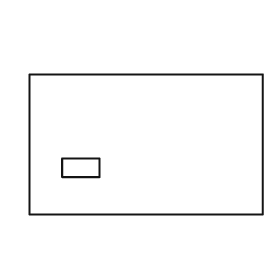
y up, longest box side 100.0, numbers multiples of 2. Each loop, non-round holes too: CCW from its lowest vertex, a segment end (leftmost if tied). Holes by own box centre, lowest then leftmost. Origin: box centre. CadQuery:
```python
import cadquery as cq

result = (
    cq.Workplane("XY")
    .moveTo(-50.0, -30.0)
    .lineTo(50.0, -30.0)
    .lineTo(50.0, 30.0)
    .lineTo(-50.0, 30.0)
    .close()
    .moveTo(-36.0, -14.0)
    .lineTo(-20.0, -14.0)
    .lineTo(-20.0, -6.0)
    .lineTo(-36.0, -6.0)
    .close()
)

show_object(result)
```